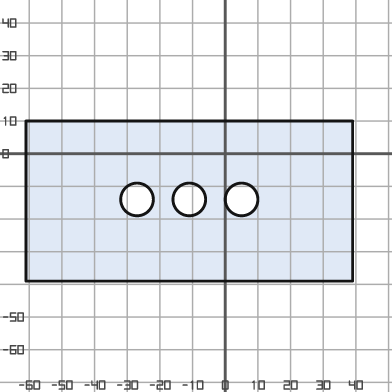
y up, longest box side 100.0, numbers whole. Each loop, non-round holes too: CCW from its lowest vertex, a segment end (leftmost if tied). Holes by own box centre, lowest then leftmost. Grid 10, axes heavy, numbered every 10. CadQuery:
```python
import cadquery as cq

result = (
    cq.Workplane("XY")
    .moveTo(-61.0, -39.0)
    .lineTo(39.0, -39.0)
    .lineTo(39.0, 10.0)
    .lineTo(-61.0, 10.0)
    .close()
    .moveTo(-27.0, -14.0)
    .circle(5.0)
    .moveTo(-11.0, -14.0)
    .circle(5.0)
    .moveTo(5.0, -14.0)
    .circle(5.0)
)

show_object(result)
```